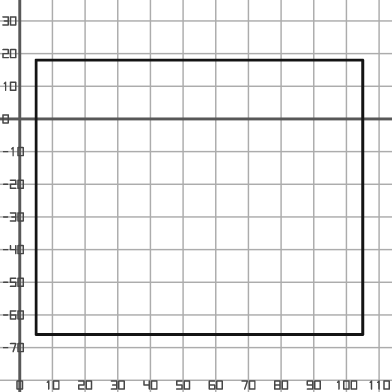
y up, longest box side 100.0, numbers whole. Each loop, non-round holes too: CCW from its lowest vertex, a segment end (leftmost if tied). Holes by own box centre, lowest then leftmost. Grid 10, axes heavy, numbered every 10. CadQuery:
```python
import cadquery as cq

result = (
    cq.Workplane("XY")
    .moveTo(5.0, -66.0)
    .lineTo(105.0, -66.0)
    .lineTo(105.0, 18.0)
    .lineTo(5.0, 18.0)
    .close()
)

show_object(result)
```